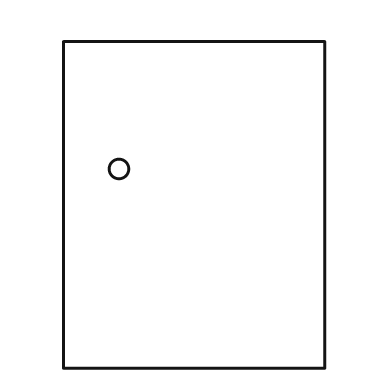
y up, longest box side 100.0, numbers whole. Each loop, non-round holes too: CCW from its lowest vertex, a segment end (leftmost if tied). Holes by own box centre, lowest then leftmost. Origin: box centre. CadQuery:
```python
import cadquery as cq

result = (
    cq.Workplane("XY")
    .moveTo(-40.0, -50.0)
    .lineTo(40.0, -50.0)
    .lineTo(40.0, 50.0)
    .lineTo(-40.0, 50.0)
    .close()
    .moveTo(-23.0, 11.0)
    .circle(3.0)
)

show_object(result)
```